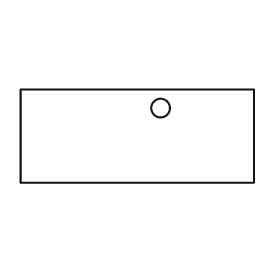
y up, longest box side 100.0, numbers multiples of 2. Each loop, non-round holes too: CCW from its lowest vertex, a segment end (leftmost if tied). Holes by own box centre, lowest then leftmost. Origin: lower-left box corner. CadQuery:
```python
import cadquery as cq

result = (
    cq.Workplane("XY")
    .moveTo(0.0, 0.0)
    .lineTo(100.0, 0.0)
    .lineTo(100.0, 40.0)
    .lineTo(0.0, 40.0)
    .close()
    .moveTo(60.0, 32.0)
    .circle(4.0)
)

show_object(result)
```